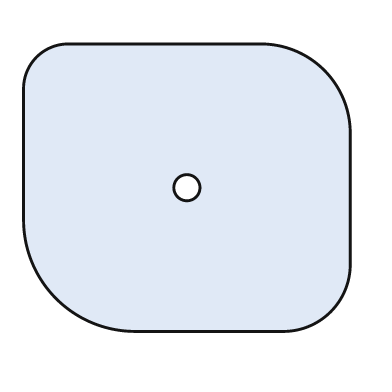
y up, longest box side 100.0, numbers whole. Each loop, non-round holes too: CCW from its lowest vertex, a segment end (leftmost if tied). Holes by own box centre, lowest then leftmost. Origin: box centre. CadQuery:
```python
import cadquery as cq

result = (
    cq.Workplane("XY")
    .moveTo(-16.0, -44.0)
    .lineTo(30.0, -44.0)
    .threePointArc((44.0, -38.0), (50.0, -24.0))
    .lineTo(50.0, 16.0)
    .threePointArc((42.0, 36.0), (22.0, 44.0))
    .lineTo(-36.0, 44.0)
    .threePointArc((-46.0, 40.0), (-50.0, 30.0))
    .lineTo(-50.0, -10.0)
    .threePointArc((-40.0, -34.0), (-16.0, -44.0))
    .close()
    .moveTo(0.0, 0.0)
    .circle(4.0)
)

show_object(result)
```